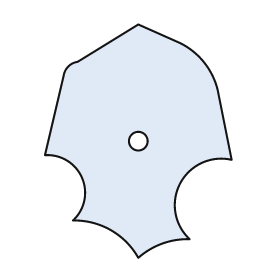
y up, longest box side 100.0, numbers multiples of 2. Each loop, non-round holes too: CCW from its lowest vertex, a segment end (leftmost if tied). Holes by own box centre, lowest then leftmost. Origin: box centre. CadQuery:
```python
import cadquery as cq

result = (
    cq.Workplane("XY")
    .moveTo(0.0, -50.0)
    .threePointArc((10.0, -44.0), (22.0, -42.0))
    .threePointArc((18.0, -18.0), (40.0, -8.0))
    .lineTo(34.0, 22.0)
    .threePointArc((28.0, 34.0), (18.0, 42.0))
    .lineTo(0.0, 50.0)
    .lineTo(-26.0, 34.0)
    .threePointArc((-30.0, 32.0), (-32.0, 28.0))
    .lineTo(-40.0, -6.0)
    .threePointArc((-24.0, -16.0), (-28.0, -34.0))
    .threePointArc((-12.0, -38.0), (0.0, -50.0))
    .close()
    .moveTo(0.0, 0.0)
    .circle(4.0)
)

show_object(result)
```